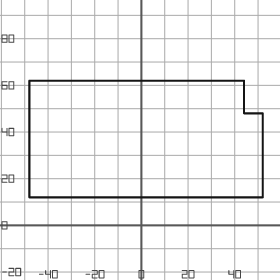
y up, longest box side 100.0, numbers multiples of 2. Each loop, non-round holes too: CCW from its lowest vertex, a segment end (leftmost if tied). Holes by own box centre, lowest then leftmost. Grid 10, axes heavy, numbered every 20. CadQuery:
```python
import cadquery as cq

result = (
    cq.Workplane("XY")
    .moveTo(-48.0, 12.0)
    .lineTo(52.0, 12.0)
    .lineTo(52.0, 48.0)
    .lineTo(44.0, 48.0)
    .lineTo(44.0, 62.0)
    .lineTo(-48.0, 62.0)
    .close()
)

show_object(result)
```